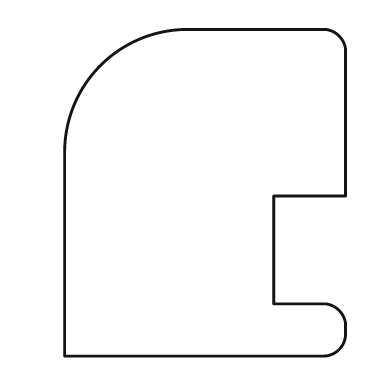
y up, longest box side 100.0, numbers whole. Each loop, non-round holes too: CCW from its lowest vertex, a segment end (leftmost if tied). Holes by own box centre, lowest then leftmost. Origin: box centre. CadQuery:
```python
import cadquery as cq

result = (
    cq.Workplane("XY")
    .moveTo(-43.0, -50.0)
    .lineTo(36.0, -50.0)
    .threePointArc((41.0, -48.0), (43.0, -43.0))
    .lineTo(43.0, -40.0)
    .threePointArc((41.0, -36.0), (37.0, -34.0))
    .lineTo(21.0, -34.0)
    .lineTo(21.0, -1.0)
    .lineTo(43.0, -1.0)
    .lineTo(43.0, 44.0)
    .threePointArc((41.0, 48.0), (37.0, 50.0))
    .lineTo(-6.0, 50.0)
    .threePointArc((-32.0, 39.0), (-43.0, 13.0))
    .close()
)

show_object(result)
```